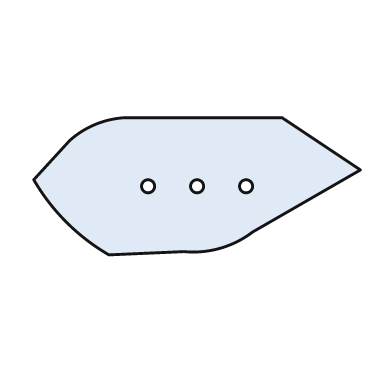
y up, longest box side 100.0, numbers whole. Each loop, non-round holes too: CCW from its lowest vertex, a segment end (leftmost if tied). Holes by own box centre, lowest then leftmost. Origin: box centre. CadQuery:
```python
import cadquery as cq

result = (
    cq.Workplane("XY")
    .moveTo(-27.0, -21.0)
    .lineTo(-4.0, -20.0)
    .threePointArc((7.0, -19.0), (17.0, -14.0))
    .lineTo(50.0, 5.0)
    .lineTo(26.0, 21.0)
    .lineTo(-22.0, 21.0)
    .threePointArc((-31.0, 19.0), (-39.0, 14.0))
    .lineTo(-50.0, 2.0)
    .threePointArc((-40.0, -11.0), (-27.0, -21.0))
    .close()
    .moveTo(-15.0, 0.0)
    .circle(2.0)
    .moveTo(0.0, 0.0)
    .circle(2.0)
    .moveTo(15.0, 0.0)
    .circle(2.0)
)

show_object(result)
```